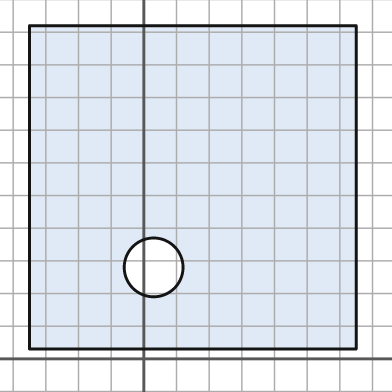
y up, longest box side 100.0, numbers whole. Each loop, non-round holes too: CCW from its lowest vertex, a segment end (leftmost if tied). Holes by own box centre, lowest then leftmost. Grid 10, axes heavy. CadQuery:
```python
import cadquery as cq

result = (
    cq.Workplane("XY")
    .moveTo(-35.0, 3.0)
    .lineTo(65.0, 3.0)
    .lineTo(65.0, 102.0)
    .lineTo(-35.0, 102.0)
    .close()
    .moveTo(3.0, 28.0)
    .circle(9.0)
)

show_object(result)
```